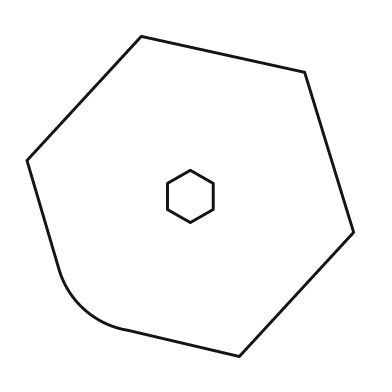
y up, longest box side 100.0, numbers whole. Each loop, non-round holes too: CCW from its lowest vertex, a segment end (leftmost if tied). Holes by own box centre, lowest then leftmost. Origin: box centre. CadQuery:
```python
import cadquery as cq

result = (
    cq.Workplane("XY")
    .moveTo(15.0, -49.0)
    .lineTo(50.0, -11.0)
    .lineTo(35.0, 38.0)
    .lineTo(-15.0, 49.0)
    .lineTo(-50.0, 11.0)
    .lineTo(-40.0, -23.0)
    .threePointArc((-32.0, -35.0), (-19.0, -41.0))
    .close()
    .moveTo(0.0, -8.0)
    .lineTo(7.0, -4.0)
    .lineTo(7.0, 4.0)
    .lineTo(0.0, 8.0)
    .lineTo(-7.0, 4.0)
    .lineTo(-7.0, -4.0)
    .close()
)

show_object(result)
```